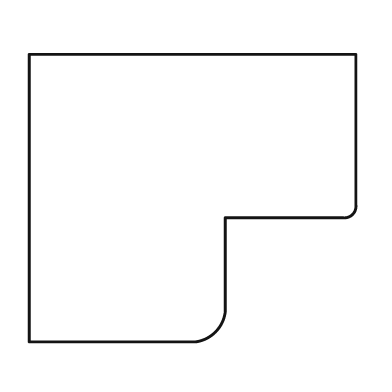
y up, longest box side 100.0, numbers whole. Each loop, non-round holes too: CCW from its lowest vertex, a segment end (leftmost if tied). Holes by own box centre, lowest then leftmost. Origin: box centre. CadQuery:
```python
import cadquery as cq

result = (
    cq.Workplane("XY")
    .moveTo(-50.0, -44.0)
    .lineTo(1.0, -44.0)
    .threePointArc((7.0, -41.0), (10.0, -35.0))
    .lineTo(10.0, -6.0)
    .lineTo(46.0, -6.0)
    .threePointArc((49.0, -5.0), (50.0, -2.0))
    .lineTo(50.0, 44.0)
    .lineTo(-50.0, 44.0)
    .close()
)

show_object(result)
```